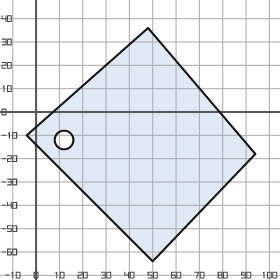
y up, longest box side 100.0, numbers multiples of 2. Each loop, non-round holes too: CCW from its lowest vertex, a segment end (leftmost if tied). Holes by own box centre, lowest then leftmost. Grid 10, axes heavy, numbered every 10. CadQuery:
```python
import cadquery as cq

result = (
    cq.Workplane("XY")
    .moveTo(50.0, -64.0)
    .lineTo(94.0, -18.0)
    .lineTo(48.0, 36.0)
    .lineTo(-4.0, -10.0)
    .close()
    .moveTo(12.0, -12.0)
    .circle(4.0)
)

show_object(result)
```